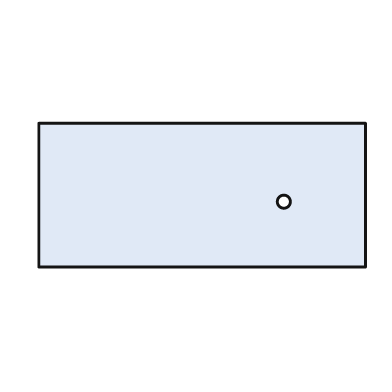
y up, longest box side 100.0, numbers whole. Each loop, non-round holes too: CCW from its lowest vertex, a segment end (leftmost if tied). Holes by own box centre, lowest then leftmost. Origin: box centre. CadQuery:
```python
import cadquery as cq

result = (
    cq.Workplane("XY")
    .moveTo(-50.0, -22.0)
    .lineTo(50.0, -22.0)
    .lineTo(50.0, 22.0)
    .lineTo(-50.0, 22.0)
    .close()
    .moveTo(25.0, -2.0)
    .circle(2.0)
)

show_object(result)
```